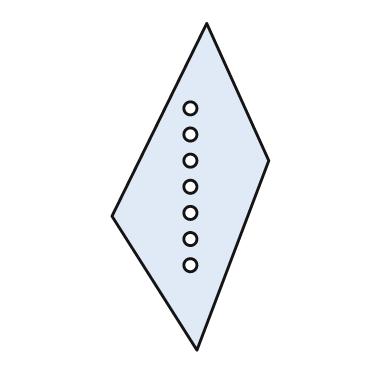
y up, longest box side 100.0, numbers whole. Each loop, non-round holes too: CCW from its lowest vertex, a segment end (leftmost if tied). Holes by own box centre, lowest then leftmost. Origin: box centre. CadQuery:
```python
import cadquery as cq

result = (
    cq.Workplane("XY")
    .moveTo(2.0, -50.0)
    .lineTo(24.0, 8.0)
    .lineTo(5.0, 50.0)
    .lineTo(-24.0, -9.0)
    .close()
    .moveTo(0.0, -24.0)
    .circle(2.0)
    .moveTo(0.0, -16.0)
    .circle(2.0)
    .moveTo(0.0, -8.0)
    .circle(2.0)
    .moveTo(0.0, 0.0)
    .circle(2.0)
    .moveTo(0.0, 8.0)
    .circle(2.0)
    .moveTo(0.0, 16.0)
    .circle(2.0)
    .moveTo(0.0, 24.0)
    .circle(2.0)
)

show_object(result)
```